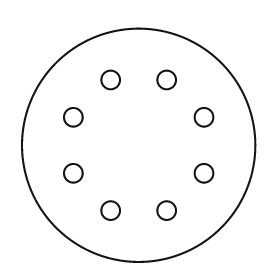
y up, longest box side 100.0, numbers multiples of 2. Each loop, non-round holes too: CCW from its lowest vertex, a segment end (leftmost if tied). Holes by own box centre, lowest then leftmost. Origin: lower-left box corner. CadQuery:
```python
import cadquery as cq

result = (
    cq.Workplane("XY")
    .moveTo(50.0, 50.0)
    .circle(50.0)
    .moveTo(38.0, 22.0)
    .circle(4.0)
    .moveTo(62.0, 22.0)
    .circle(4.0)
    .moveTo(22.0, 38.0)
    .circle(4.0)
    .moveTo(78.0, 38.0)
    .circle(4.0)
    .moveTo(22.0, 62.0)
    .circle(4.0)
    .moveTo(78.0, 62.0)
    .circle(4.0)
    .moveTo(38.0, 78.0)
    .circle(4.0)
    .moveTo(62.0, 78.0)
    .circle(4.0)
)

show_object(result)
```